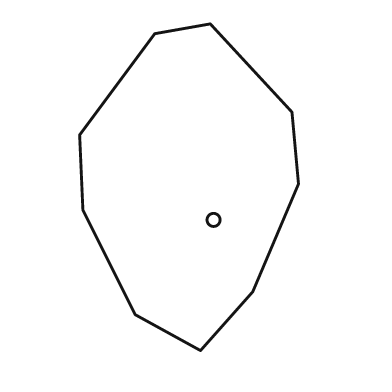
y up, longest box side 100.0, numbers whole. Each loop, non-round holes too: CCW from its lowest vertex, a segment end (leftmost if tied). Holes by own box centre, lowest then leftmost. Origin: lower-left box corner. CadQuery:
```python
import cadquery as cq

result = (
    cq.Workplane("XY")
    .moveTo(37.0, 0.0)
    .lineTo(53.0, 18.0)
    .lineTo(67.0, 51.0)
    .lineTo(65.0, 73.0)
    .lineTo(40.0, 100.0)
    .lineTo(23.0, 97.0)
    .lineTo(0.0, 66.0)
    .lineTo(1.0, 43.0)
    .lineTo(17.0, 11.0)
    .close()
    .moveTo(41.0, 40.0)
    .circle(2.0)
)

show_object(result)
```